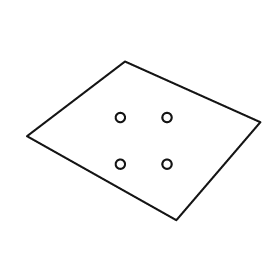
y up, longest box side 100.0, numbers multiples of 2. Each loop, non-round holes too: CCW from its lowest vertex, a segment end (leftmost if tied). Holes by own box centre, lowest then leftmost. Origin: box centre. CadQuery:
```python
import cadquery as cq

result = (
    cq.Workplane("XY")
    .moveTo(14.0, -34.0)
    .lineTo(50.0, 8.0)
    .lineTo(-8.0, 34.0)
    .lineTo(-50.0, 2.0)
    .close()
    .moveTo(-10.0, -10.0)
    .circle(2.0)
    .moveTo(10.0, -10.0)
    .circle(2.0)
    .moveTo(-10.0, 10.0)
    .circle(2.0)
    .moveTo(10.0, 10.0)
    .circle(2.0)
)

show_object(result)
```